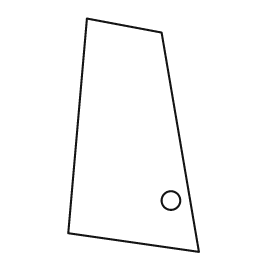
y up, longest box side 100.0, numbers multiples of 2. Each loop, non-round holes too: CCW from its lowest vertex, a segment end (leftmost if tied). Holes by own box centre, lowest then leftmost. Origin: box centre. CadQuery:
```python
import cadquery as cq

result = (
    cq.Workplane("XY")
    .moveTo(28.0, -50.0)
    .lineTo(12.0, 44.0)
    .lineTo(-20.0, 50.0)
    .lineTo(-28.0, -42.0)
    .close()
    .moveTo(16.0, -28.0)
    .circle(4.0)
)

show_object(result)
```